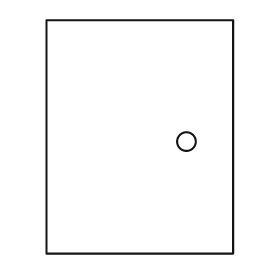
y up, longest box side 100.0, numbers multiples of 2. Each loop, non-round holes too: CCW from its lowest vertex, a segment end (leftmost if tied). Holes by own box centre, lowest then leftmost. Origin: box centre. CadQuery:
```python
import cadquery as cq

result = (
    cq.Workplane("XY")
    .moveTo(-40.0, -50.0)
    .lineTo(40.0, -50.0)
    .lineTo(40.0, 50.0)
    .lineTo(-40.0, 50.0)
    .close()
    .moveTo(20.0, -2.0)
    .circle(4.0)
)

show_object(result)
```